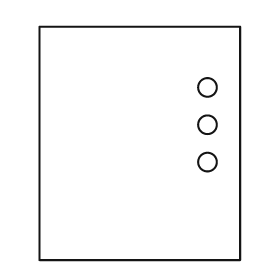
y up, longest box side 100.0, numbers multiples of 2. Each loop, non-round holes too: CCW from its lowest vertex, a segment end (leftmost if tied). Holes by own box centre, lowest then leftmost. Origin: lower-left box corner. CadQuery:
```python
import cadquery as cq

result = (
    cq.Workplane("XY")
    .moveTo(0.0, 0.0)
    .lineTo(86.0, 0.0)
    .lineTo(86.0, 100.0)
    .lineTo(0.0, 100.0)
    .close()
    .moveTo(72.0, 42.0)
    .circle(4.0)
    .moveTo(72.0, 58.0)
    .circle(4.0)
    .moveTo(72.0, 74.0)
    .circle(4.0)
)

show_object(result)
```